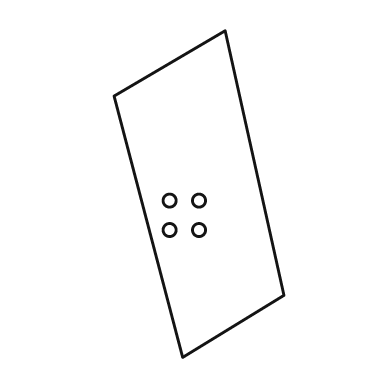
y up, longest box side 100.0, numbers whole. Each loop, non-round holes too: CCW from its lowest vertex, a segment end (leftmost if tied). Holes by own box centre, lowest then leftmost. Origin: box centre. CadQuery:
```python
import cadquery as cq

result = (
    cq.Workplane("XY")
    .moveTo(-5.0, -50.0)
    .lineTo(26.0, -31.0)
    .lineTo(8.0, 50.0)
    .lineTo(-26.0, 30.0)
    .close()
    .moveTo(-9.0, -11.0)
    .circle(2.0)
    .moveTo(0.0, -11.0)
    .circle(2.0)
    .moveTo(-9.0, -2.0)
    .circle(2.0)
    .moveTo(0.0, -2.0)
    .circle(2.0)
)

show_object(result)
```